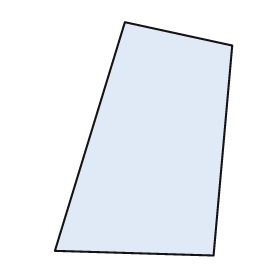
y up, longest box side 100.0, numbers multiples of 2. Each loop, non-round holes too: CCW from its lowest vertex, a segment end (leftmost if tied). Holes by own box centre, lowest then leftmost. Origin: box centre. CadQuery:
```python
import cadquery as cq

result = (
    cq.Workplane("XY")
    .moveTo(30.0, -50.0)
    .lineTo(38.0, 40.0)
    .lineTo(-8.0, 50.0)
    .lineTo(-38.0, -48.0)
    .close()
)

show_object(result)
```